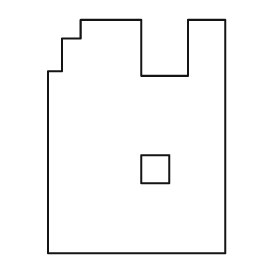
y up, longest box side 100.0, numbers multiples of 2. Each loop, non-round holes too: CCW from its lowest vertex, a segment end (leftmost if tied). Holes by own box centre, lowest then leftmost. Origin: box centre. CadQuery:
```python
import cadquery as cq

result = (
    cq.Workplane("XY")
    .moveTo(-38.0, -50.0)
    .lineTo(38.0, -50.0)
    .lineTo(38.0, 50.0)
    .lineTo(22.0, 50.0)
    .lineTo(22.0, 26.0)
    .lineTo(2.0, 26.0)
    .lineTo(2.0, 50.0)
    .lineTo(-24.0, 50.0)
    .lineTo(-24.0, 42.0)
    .lineTo(-32.0, 42.0)
    .lineTo(-32.0, 28.0)
    .lineTo(-38.0, 28.0)
    .close()
    .moveTo(2.0, -20.0)
    .lineTo(14.0, -20.0)
    .lineTo(14.0, -8.0)
    .lineTo(2.0, -8.0)
    .close()
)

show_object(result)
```